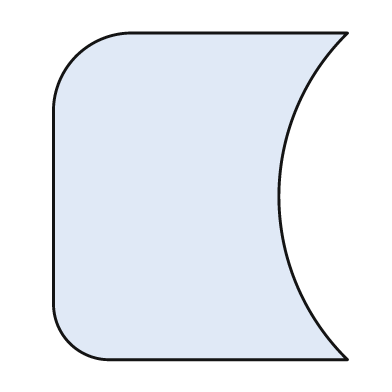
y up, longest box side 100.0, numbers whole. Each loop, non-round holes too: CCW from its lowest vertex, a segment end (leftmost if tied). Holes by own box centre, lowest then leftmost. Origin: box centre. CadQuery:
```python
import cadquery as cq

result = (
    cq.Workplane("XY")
    .moveTo(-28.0, -50.0)
    .lineTo(45.0, -50.0)
    .threePointArc((24.0, 0.0), (45.0, 50.0))
    .lineTo(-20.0, 50.0)
    .threePointArc((-38.0, 43.0), (-45.0, 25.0))
    .lineTo(-45.0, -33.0)
    .threePointArc((-40.0, -45.0), (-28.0, -50.0))
    .close()
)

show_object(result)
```